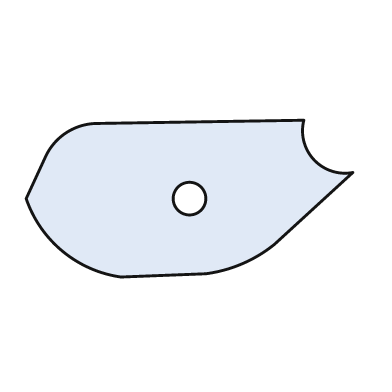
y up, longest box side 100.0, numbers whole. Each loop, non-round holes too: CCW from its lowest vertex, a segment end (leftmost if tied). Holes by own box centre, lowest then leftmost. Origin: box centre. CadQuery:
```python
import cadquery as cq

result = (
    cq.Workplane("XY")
    .moveTo(-21.0, -24.0)
    .lineTo(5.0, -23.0)
    .threePointArc((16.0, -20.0), (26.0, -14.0))
    .lineTo(50.0, 8.0)
    .threePointArc((38.0, 12.0), (35.0, 24.0))
    .lineTo(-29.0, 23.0)
    .threePointArc((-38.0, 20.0), (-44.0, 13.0))
    .lineTo(-50.0, 0.0)
    .threePointArc((-39.0, -16.0), (-21.0, -24.0))
    .close()
    .moveTo(0.0, 0.0)
    .circle(5.0)
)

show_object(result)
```